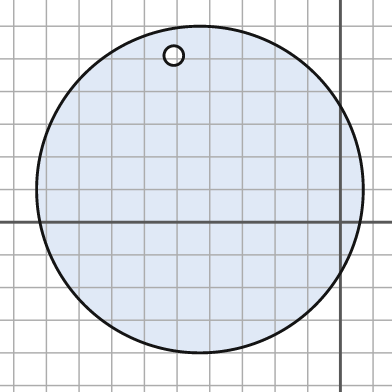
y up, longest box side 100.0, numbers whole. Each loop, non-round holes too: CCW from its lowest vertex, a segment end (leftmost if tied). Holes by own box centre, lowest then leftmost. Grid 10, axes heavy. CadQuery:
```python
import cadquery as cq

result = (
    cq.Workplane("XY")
    .moveTo(-43.0, 10.0)
    .circle(50.0)
    .moveTo(-51.0, 51.0)
    .circle(3.0)
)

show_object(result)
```